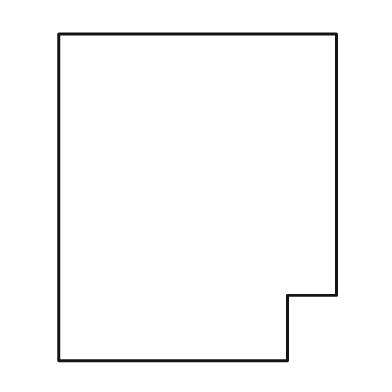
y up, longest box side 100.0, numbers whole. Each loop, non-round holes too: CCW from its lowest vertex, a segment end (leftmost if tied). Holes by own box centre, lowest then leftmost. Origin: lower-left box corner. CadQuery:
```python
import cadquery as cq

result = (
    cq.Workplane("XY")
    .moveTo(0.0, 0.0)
    .lineTo(70.0, 0.0)
    .lineTo(70.0, 20.0)
    .lineTo(85.0, 20.0)
    .lineTo(85.0, 100.0)
    .lineTo(0.0, 100.0)
    .close()
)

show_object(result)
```